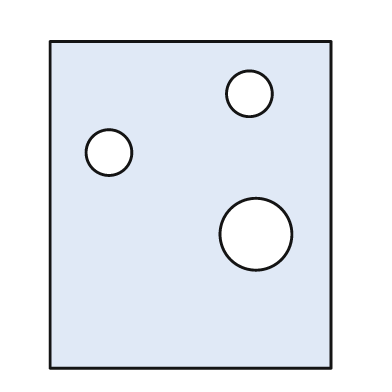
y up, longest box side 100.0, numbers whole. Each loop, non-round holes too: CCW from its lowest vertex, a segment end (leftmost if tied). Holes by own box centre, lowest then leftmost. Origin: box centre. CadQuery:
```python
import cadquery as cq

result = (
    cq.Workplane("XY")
    .moveTo(-43.0, -50.0)
    .lineTo(43.0, -50.0)
    .lineTo(43.0, 50.0)
    .lineTo(-43.0, 50.0)
    .close()
    .moveTo(20.0, -9.0)
    .circle(11.0)
    .moveTo(-25.0, 16.0)
    .circle(7.0)
    .moveTo(18.0, 34.0)
    .circle(7.0)
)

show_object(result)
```